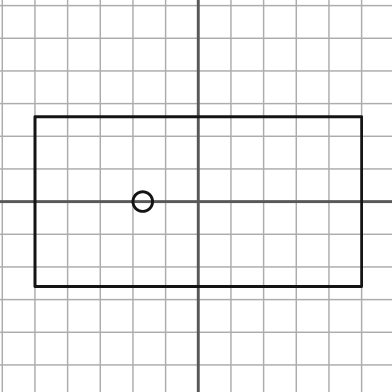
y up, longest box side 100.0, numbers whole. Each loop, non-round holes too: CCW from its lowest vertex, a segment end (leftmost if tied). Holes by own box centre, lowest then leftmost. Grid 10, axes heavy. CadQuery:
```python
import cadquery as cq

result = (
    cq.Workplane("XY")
    .moveTo(-50.0, -26.0)
    .lineTo(50.0, -26.0)
    .lineTo(50.0, 26.0)
    .lineTo(-50.0, 26.0)
    .close()
    .moveTo(-17.0, 0.0)
    .circle(3.0)
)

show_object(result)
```